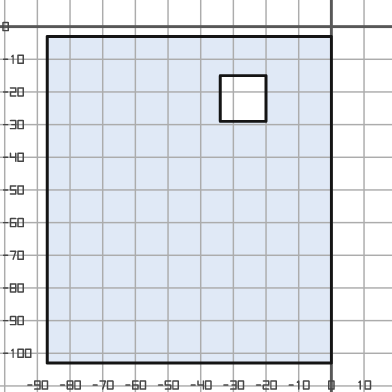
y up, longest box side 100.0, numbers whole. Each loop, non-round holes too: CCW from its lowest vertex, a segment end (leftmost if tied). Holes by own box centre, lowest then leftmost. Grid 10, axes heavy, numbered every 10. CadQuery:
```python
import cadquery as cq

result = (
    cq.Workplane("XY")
    .moveTo(-87.0, -103.0)
    .lineTo(0.0, -103.0)
    .lineTo(0.0, -3.0)
    .lineTo(-87.0, -3.0)
    .close()
    .moveTo(-34.0, -29.0)
    .lineTo(-20.0, -29.0)
    .lineTo(-20.0, -15.0)
    .lineTo(-34.0, -15.0)
    .close()
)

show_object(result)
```